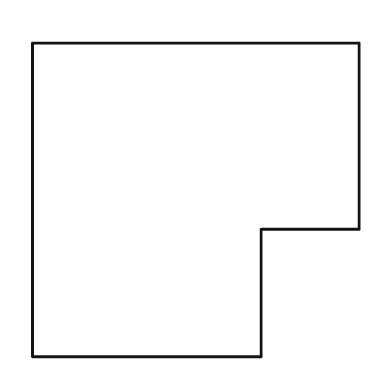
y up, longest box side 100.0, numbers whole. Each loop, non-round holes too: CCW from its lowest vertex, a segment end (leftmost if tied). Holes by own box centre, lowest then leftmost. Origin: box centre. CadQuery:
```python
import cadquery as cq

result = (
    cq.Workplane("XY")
    .moveTo(-50.0, -48.0)
    .lineTo(20.0, -48.0)
    .lineTo(20.0, -9.0)
    .lineTo(50.0, -9.0)
    .lineTo(50.0, 48.0)
    .lineTo(-50.0, 48.0)
    .close()
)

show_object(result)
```